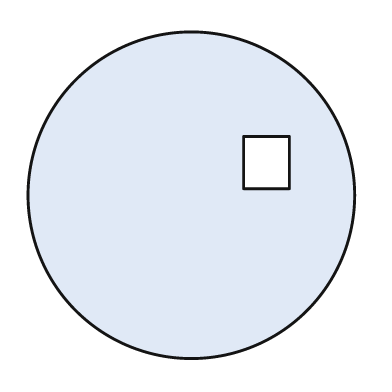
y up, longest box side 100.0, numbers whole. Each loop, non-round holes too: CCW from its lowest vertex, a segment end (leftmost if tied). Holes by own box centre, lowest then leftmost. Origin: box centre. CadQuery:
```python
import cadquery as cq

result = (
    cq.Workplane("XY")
    .moveTo(0.0, 0.0)
    .circle(50.0)
    .moveTo(16.0, 2.0)
    .lineTo(30.0, 2.0)
    .lineTo(30.0, 18.0)
    .lineTo(16.0, 18.0)
    .close()
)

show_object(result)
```